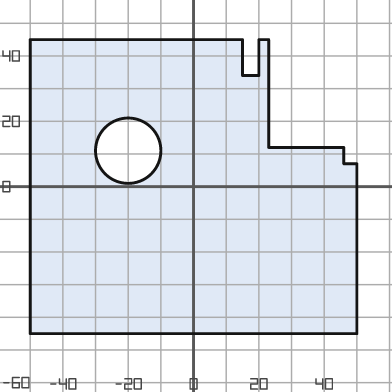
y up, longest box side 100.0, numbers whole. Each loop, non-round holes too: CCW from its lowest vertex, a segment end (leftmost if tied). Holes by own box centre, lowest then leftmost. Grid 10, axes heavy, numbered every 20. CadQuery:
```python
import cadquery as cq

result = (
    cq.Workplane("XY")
    .moveTo(-50.0, -45.0)
    .lineTo(50.0, -45.0)
    .lineTo(50.0, 7.0)
    .lineTo(46.0, 7.0)
    .lineTo(46.0, 12.0)
    .lineTo(23.0, 12.0)
    .lineTo(23.0, 45.0)
    .lineTo(20.0, 45.0)
    .lineTo(20.0, 34.0)
    .lineTo(15.0, 34.0)
    .lineTo(15.0, 45.0)
    .lineTo(-50.0, 45.0)
    .close()
    .moveTo(-20.0, 11.0)
    .circle(10.0)
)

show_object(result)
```